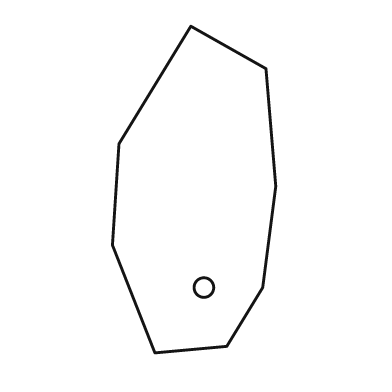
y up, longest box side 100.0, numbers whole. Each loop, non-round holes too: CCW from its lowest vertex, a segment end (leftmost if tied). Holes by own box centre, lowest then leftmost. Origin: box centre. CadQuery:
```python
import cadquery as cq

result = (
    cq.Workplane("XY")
    .moveTo(-12.0, -50.0)
    .lineTo(10.0, -48.0)
    .lineTo(21.0, -30.0)
    .lineTo(25.0, 1.0)
    .lineTo(22.0, 37.0)
    .lineTo(-1.0, 50.0)
    .lineTo(-23.0, 14.0)
    .lineTo(-25.0, -17.0)
    .close()
    .moveTo(3.0, -30.0)
    .circle(3.0)
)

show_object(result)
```